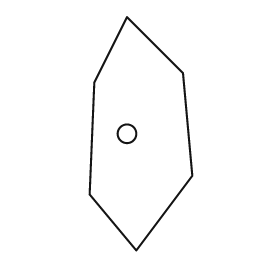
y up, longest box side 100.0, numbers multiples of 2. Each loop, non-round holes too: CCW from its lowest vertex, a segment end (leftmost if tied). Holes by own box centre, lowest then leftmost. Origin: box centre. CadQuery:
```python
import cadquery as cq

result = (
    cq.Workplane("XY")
    .moveTo(-2.0, -50.0)
    .lineTo(22.0, -18.0)
    .lineTo(18.0, 26.0)
    .lineTo(-6.0, 50.0)
    .lineTo(-20.0, 22.0)
    .lineTo(-22.0, -26.0)
    .close()
    .moveTo(-6.0, 0.0)
    .circle(4.0)
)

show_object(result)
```